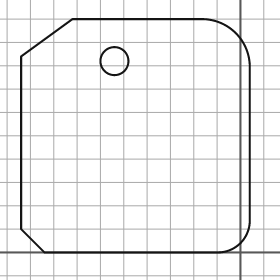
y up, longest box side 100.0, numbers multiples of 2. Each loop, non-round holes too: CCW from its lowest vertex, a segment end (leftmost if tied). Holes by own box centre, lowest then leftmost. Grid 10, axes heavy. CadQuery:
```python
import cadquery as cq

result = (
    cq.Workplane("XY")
    .moveTo(-84.0, 0.0)
    .lineTo(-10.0, 0.0)
    .threePointArc((0.0, 4.0), (4.0, 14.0))
    .lineTo(4.0, 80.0)
    .threePointArc((-2.0, 94.0), (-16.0, 100.0))
    .lineTo(-72.0, 100.0)
    .lineTo(-94.0, 84.0)
    .lineTo(-94.0, 10.0)
    .close()
    .moveTo(-54.0, 82.0)
    .circle(6.0)
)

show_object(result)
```